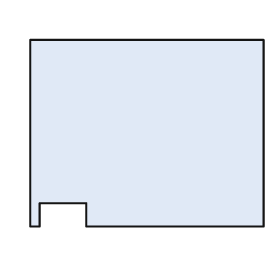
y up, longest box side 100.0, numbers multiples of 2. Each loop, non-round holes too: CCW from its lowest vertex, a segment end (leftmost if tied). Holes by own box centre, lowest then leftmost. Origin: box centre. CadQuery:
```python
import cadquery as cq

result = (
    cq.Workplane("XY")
    .moveTo(-50.0, -40.0)
    .lineTo(-46.0, -40.0)
    .lineTo(-46.0, -30.0)
    .lineTo(-26.0, -30.0)
    .lineTo(-26.0, -40.0)
    .lineTo(50.0, -40.0)
    .lineTo(50.0, 40.0)
    .lineTo(-50.0, 40.0)
    .close()
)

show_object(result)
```